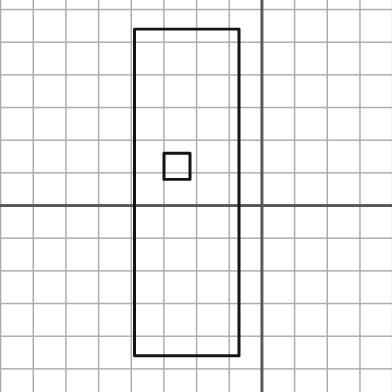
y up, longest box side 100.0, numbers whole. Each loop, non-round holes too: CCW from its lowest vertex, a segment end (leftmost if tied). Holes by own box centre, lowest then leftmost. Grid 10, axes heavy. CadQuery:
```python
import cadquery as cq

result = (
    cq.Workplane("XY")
    .moveTo(-39.0, -46.0)
    .lineTo(-7.0, -46.0)
    .lineTo(-7.0, 54.0)
    .lineTo(-39.0, 54.0)
    .close()
    .moveTo(-30.0, 8.0)
    .lineTo(-22.0, 8.0)
    .lineTo(-22.0, 16.0)
    .lineTo(-30.0, 16.0)
    .close()
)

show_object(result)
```